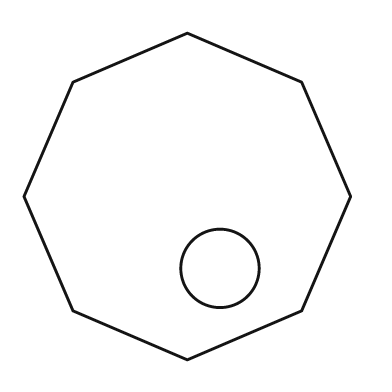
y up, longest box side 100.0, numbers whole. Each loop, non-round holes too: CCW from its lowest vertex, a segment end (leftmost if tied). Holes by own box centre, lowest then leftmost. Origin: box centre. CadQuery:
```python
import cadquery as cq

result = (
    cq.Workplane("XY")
    .moveTo(0.0, -50.0)
    .lineTo(35.0, -35.0)
    .lineTo(50.0, 0.0)
    .lineTo(35.0, 35.0)
    .lineTo(0.0, 50.0)
    .lineTo(-35.0, 35.0)
    .lineTo(-50.0, 0.0)
    .lineTo(-35.0, -35.0)
    .close()
    .moveTo(10.0, -22.0)
    .circle(12.0)
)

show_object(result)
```